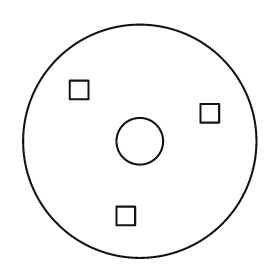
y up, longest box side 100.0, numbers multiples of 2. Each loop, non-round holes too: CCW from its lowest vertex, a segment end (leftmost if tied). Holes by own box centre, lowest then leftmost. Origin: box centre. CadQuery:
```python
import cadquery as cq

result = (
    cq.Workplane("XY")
    .moveTo(0.0, 0.0)
    .circle(50.0)
    .moveTo(-10.0, -36.0)
    .lineTo(-2.0, -36.0)
    .lineTo(-2.0, -28.0)
    .lineTo(-10.0, -28.0)
    .close()
    .moveTo(0.0, 0.0)
    .circle(10.0)
    .moveTo(26.0, 8.0)
    .lineTo(34.0, 8.0)
    .lineTo(34.0, 16.0)
    .lineTo(26.0, 16.0)
    .close()
    .moveTo(-30.0, 18.0)
    .lineTo(-22.0, 18.0)
    .lineTo(-22.0, 26.0)
    .lineTo(-30.0, 26.0)
    .close()
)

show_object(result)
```